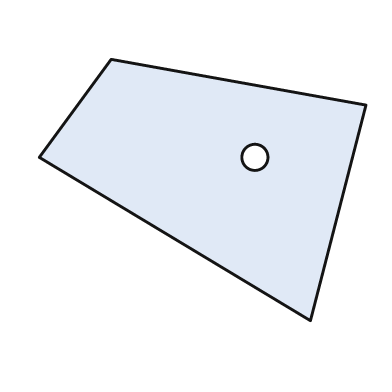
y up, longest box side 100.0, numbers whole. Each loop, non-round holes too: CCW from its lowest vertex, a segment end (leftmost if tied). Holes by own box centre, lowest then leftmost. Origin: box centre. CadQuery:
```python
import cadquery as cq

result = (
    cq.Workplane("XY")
    .moveTo(33.0, -40.0)
    .lineTo(50.0, 26.0)
    .lineTo(-28.0, 40.0)
    .lineTo(-50.0, 10.0)
    .close()
    .moveTo(16.0, 10.0)
    .circle(4.0)
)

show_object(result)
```